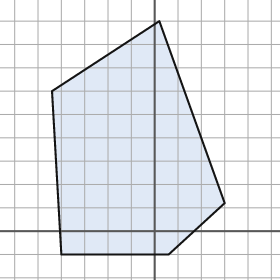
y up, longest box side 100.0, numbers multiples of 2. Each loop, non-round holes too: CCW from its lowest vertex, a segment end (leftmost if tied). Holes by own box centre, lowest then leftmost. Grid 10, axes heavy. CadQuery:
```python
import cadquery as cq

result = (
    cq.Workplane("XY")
    .moveTo(-40.0, -10.0)
    .lineTo(6.0, -10.0)
    .lineTo(30.0, 12.0)
    .lineTo(2.0, 90.0)
    .lineTo(-44.0, 60.0)
    .close()
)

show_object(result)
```